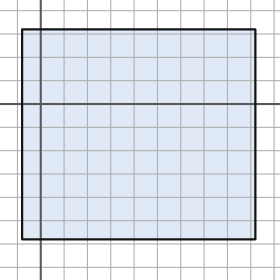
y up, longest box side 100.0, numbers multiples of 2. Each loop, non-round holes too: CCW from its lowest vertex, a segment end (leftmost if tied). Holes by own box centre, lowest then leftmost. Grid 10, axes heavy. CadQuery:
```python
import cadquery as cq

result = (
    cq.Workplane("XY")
    .moveTo(-8.0, -58.0)
    .lineTo(92.0, -58.0)
    .lineTo(92.0, 32.0)
    .lineTo(-8.0, 32.0)
    .close()
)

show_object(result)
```